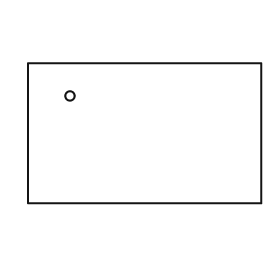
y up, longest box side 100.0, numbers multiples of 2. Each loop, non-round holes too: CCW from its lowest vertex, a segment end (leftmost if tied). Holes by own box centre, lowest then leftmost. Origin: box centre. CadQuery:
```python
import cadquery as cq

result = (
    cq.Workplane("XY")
    .moveTo(-50.0, -30.0)
    .lineTo(50.0, -30.0)
    .lineTo(50.0, 30.0)
    .lineTo(-50.0, 30.0)
    .close()
    .moveTo(-32.0, 16.0)
    .circle(2.0)
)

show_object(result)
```